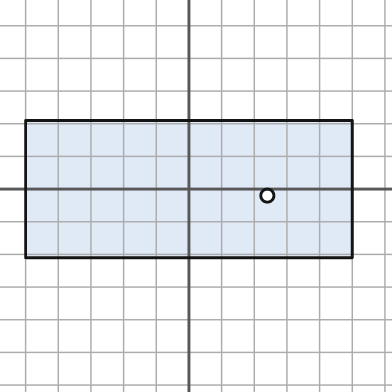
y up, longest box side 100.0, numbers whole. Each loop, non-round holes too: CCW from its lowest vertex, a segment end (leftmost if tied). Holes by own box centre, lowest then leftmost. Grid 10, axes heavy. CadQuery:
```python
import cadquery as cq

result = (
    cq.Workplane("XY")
    .moveTo(-50.0, -21.0)
    .lineTo(50.0, -21.0)
    .lineTo(50.0, 21.0)
    .lineTo(-50.0, 21.0)
    .close()
    .moveTo(24.0, -2.0)
    .circle(2.0)
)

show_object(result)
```